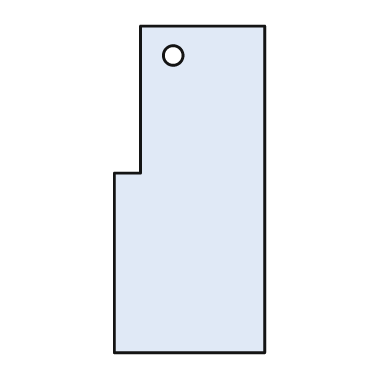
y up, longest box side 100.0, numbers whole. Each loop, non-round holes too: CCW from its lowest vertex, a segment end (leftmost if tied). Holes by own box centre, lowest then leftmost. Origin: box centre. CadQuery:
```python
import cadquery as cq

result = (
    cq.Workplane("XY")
    .moveTo(-23.0, -50.0)
    .lineTo(23.0, -50.0)
    .lineTo(23.0, 50.0)
    .lineTo(-15.0, 50.0)
    .lineTo(-15.0, 5.0)
    .lineTo(-23.0, 5.0)
    .close()
    .moveTo(-5.0, 41.0)
    .circle(3.0)
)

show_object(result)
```